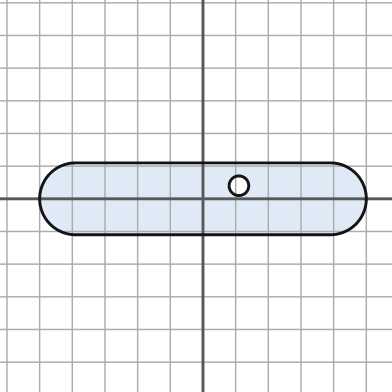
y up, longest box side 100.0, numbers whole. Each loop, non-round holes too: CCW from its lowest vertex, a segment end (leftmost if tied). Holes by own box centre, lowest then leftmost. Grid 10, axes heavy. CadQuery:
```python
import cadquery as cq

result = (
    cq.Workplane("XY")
    .moveTo(-39.0, -11.0)
    .lineTo(39.0, -11.0)
    .threePointArc((50.0, 0.0), (39.0, 11.0))
    .lineTo(-39.0, 11.0)
    .threePointArc((-50.0, 0.0), (-39.0, -11.0))
    .close()
    .moveTo(11.0, 4.0)
    .circle(3.0)
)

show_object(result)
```